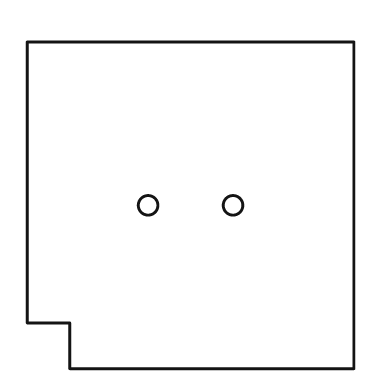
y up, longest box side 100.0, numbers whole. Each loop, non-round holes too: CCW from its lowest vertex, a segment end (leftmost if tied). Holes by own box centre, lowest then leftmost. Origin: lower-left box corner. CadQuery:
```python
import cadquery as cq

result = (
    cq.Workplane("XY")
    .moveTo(13.0, 0.0)
    .lineTo(100.0, 0.0)
    .lineTo(100.0, 100.0)
    .lineTo(0.0, 100.0)
    .lineTo(0.0, 14.0)
    .lineTo(13.0, 14.0)
    .close()
    .moveTo(37.0, 50.0)
    .circle(3.0)
    .moveTo(63.0, 50.0)
    .circle(3.0)
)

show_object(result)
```